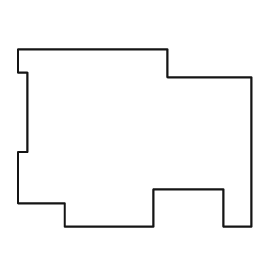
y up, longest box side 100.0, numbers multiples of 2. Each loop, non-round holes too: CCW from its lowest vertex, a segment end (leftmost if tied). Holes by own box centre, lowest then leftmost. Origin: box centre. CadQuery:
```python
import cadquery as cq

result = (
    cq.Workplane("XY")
    .moveTo(-30.0, -38.0)
    .lineTo(8.0, -38.0)
    .lineTo(8.0, -22.0)
    .lineTo(38.0, -22.0)
    .lineTo(38.0, -38.0)
    .lineTo(50.0, -38.0)
    .lineTo(50.0, 26.0)
    .lineTo(14.0, 26.0)
    .lineTo(14.0, 38.0)
    .lineTo(-50.0, 38.0)
    .lineTo(-50.0, 28.0)
    .lineTo(-46.0, 28.0)
    .lineTo(-46.0, -6.0)
    .lineTo(-50.0, -6.0)
    .lineTo(-50.0, -28.0)
    .lineTo(-30.0, -28.0)
    .close()
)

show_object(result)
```